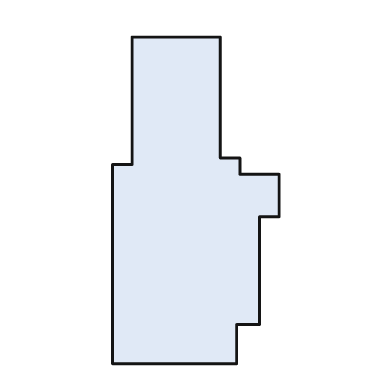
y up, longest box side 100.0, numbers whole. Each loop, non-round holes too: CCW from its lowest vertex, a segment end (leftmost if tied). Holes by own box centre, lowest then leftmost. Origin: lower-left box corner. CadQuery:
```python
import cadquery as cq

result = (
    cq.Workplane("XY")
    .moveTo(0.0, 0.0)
    .lineTo(38.0, 0.0)
    .lineTo(38.0, 12.0)
    .lineTo(45.0, 12.0)
    .lineTo(45.0, 45.0)
    .lineTo(51.0, 45.0)
    .lineTo(51.0, 58.0)
    .lineTo(39.0, 58.0)
    .lineTo(39.0, 63.0)
    .lineTo(33.0, 63.0)
    .lineTo(33.0, 100.0)
    .lineTo(6.0, 100.0)
    .lineTo(6.0, 61.0)
    .lineTo(0.0, 61.0)
    .close()
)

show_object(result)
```